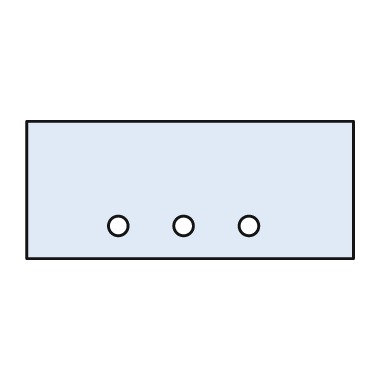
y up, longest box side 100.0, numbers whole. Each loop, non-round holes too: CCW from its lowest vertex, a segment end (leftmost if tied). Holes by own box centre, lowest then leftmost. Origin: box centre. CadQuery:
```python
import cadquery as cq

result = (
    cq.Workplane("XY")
    .moveTo(-50.0, -21.0)
    .lineTo(50.0, -21.0)
    .lineTo(50.0, 21.0)
    .lineTo(-50.0, 21.0)
    .close()
    .moveTo(-22.0, -11.0)
    .circle(3.0)
    .moveTo(-2.0, -11.0)
    .circle(3.0)
    .moveTo(18.0, -11.0)
    .circle(3.0)
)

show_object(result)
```